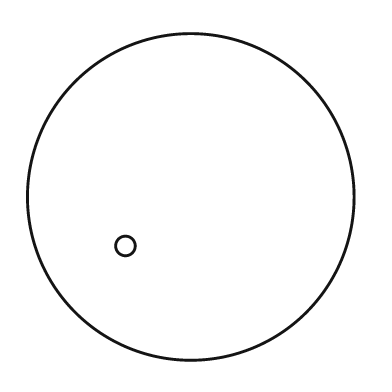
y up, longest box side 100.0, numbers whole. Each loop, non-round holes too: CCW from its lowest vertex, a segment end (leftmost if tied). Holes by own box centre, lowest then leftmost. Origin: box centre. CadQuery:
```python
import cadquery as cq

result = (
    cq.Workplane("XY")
    .moveTo(0.0, 0.0)
    .circle(50.0)
    .moveTo(-20.0, -15.0)
    .circle(3.0)
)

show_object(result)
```